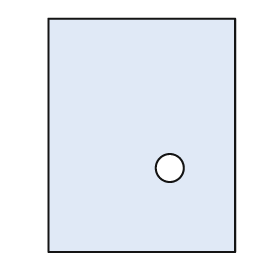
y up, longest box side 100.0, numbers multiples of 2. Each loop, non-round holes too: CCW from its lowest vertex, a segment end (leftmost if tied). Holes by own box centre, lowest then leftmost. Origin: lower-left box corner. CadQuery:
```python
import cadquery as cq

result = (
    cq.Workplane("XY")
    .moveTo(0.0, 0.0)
    .lineTo(80.0, 0.0)
    .lineTo(80.0, 100.0)
    .lineTo(0.0, 100.0)
    .close()
    .moveTo(52.0, 36.0)
    .circle(6.0)
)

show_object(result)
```